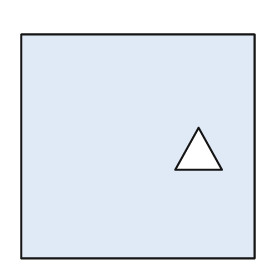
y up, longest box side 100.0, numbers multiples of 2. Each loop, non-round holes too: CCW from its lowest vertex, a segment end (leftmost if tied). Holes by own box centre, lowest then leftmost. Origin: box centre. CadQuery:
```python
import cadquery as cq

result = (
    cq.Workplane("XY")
    .moveTo(-50.0, -48.0)
    .lineTo(50.0, -48.0)
    .lineTo(50.0, 48.0)
    .lineTo(-50.0, 48.0)
    .close()
    .moveTo(16.0, -10.0)
    .lineTo(36.0, -10.0)
    .lineTo(26.0, 8.0)
    .close()
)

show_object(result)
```